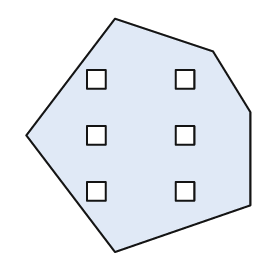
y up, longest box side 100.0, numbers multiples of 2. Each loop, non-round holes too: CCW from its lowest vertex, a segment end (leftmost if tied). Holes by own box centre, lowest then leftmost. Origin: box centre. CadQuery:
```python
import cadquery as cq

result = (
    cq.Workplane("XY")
    .moveTo(-10.0, -50.0)
    .lineTo(48.0, -30.0)
    .lineTo(48.0, 10.0)
    .lineTo(32.0, 36.0)
    .lineTo(-10.0, 50.0)
    .lineTo(-48.0, 0.0)
    .close()
    .moveTo(-22.0, -28.0)
    .lineTo(-14.0, -28.0)
    .lineTo(-14.0, -20.0)
    .lineTo(-22.0, -20.0)
    .close()
    .moveTo(16.0, -28.0)
    .lineTo(24.0, -28.0)
    .lineTo(24.0, -20.0)
    .lineTo(16.0, -20.0)
    .close()
    .moveTo(-22.0, -4.0)
    .lineTo(-14.0, -4.0)
    .lineTo(-14.0, 4.0)
    .lineTo(-22.0, 4.0)
    .close()
    .moveTo(16.0, -4.0)
    .lineTo(24.0, -4.0)
    .lineTo(24.0, 4.0)
    .lineTo(16.0, 4.0)
    .close()
    .moveTo(-22.0, 20.0)
    .lineTo(-14.0, 20.0)
    .lineTo(-14.0, 28.0)
    .lineTo(-22.0, 28.0)
    .close()
    .moveTo(16.0, 20.0)
    .lineTo(24.0, 20.0)
    .lineTo(24.0, 28.0)
    .lineTo(16.0, 28.0)
    .close()
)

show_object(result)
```